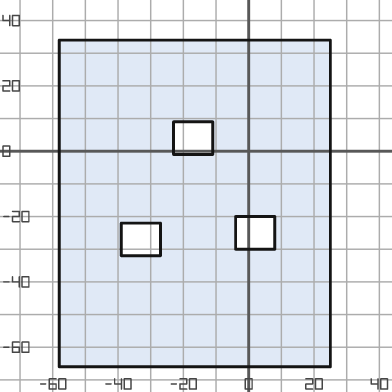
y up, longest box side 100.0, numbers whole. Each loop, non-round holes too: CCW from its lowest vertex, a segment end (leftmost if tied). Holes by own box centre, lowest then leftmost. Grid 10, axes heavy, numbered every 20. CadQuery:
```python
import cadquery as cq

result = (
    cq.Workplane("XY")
    .moveTo(-58.0, -66.0)
    .lineTo(25.0, -66.0)
    .lineTo(25.0, 34.0)
    .lineTo(-58.0, 34.0)
    .close()
    .moveTo(-39.0, -32.0)
    .lineTo(-27.0, -32.0)
    .lineTo(-27.0, -22.0)
    .lineTo(-39.0, -22.0)
    .close()
    .moveTo(-4.0, -30.0)
    .lineTo(8.0, -30.0)
    .lineTo(8.0, -20.0)
    .lineTo(-4.0, -20.0)
    .close()
    .moveTo(-23.0, -1.0)
    .lineTo(-11.0, -1.0)
    .lineTo(-11.0, 9.0)
    .lineTo(-23.0, 9.0)
    .close()
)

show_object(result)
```